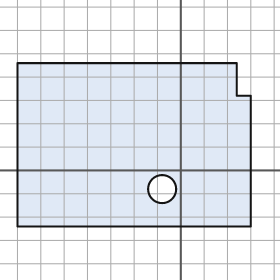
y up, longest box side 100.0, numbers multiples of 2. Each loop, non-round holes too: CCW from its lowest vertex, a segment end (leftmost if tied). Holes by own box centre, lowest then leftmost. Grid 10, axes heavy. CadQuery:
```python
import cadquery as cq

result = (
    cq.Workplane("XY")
    .moveTo(-70.0, -24.0)
    .lineTo(30.0, -24.0)
    .lineTo(30.0, 32.0)
    .lineTo(24.0, 32.0)
    .lineTo(24.0, 46.0)
    .lineTo(-70.0, 46.0)
    .close()
    .moveTo(-8.0, -8.0)
    .circle(6.0)
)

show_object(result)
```